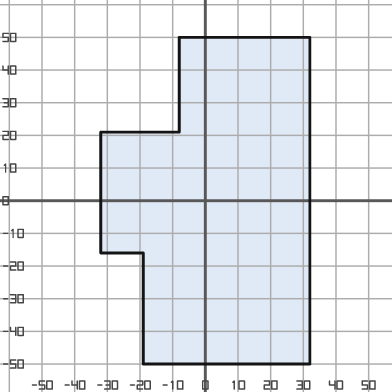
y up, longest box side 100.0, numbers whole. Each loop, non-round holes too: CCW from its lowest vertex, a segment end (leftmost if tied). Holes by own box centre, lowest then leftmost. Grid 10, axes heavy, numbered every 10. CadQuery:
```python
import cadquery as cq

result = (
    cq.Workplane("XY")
    .moveTo(-19.0, -50.0)
    .lineTo(32.0, -50.0)
    .lineTo(32.0, 50.0)
    .lineTo(-8.0, 50.0)
    .lineTo(-8.0, 21.0)
    .lineTo(-32.0, 21.0)
    .lineTo(-32.0, -16.0)
    .lineTo(-19.0, -16.0)
    .close()
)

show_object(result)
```